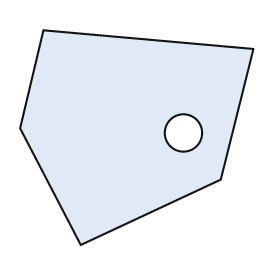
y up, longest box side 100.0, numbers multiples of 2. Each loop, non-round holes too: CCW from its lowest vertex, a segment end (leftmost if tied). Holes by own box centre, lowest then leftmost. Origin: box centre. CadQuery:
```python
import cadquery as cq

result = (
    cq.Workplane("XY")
    .moveTo(-24.0, -46.0)
    .lineTo(36.0, -18.0)
    .lineTo(50.0, 38.0)
    .lineTo(-40.0, 46.0)
    .lineTo(-50.0, 4.0)
    .close()
    .moveTo(20.0, 2.0)
    .circle(8.0)
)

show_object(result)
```